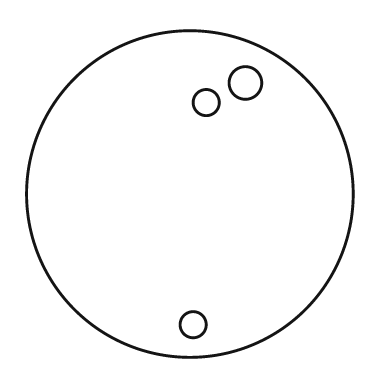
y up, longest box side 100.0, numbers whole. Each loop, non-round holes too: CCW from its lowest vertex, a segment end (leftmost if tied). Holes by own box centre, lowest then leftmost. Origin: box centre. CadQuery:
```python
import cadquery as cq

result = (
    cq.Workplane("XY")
    .moveTo(0.0, 0.0)
    .circle(50.0)
    .moveTo(1.0, -40.0)
    .circle(4.0)
    .moveTo(5.0, 28.0)
    .circle(4.0)
    .moveTo(17.0, 34.0)
    .circle(5.0)
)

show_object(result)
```